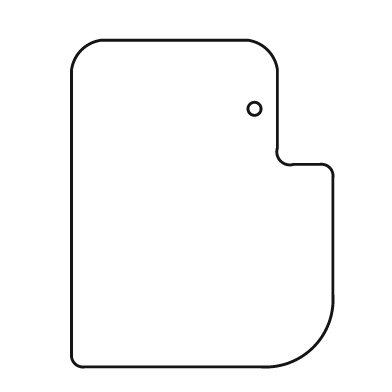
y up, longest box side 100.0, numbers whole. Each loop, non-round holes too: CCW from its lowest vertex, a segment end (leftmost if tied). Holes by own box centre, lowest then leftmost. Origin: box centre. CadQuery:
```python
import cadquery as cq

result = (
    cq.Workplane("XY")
    .moveTo(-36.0, -50.0)
    .lineTo(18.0, -50.0)
    .threePointArc((34.0, -44.0), (40.0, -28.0))
    .lineTo(40.0, 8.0)
    .threePointArc((39.0, 11.0), (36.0, 12.0))
    .lineTo(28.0, 12.0)
    .threePointArc((24.0, 13.0), (23.0, 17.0))
    .lineTo(23.0, 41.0)
    .threePointArc((20.0, 47.0), (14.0, 50.0))
    .lineTo(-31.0, 50.0)
    .threePointArc((-37.0, 47.0), (-40.0, 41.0))
    .lineTo(-40.0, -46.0)
    .threePointArc((-39.0, -49.0), (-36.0, -50.0))
    .close()
    .moveTo(16.0, 29.0)
    .circle(2.0)
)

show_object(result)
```